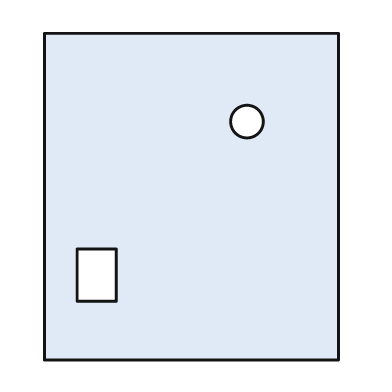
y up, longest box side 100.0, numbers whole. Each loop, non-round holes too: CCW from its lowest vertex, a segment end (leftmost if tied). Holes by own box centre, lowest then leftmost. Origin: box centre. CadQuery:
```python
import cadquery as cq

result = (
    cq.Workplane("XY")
    .moveTo(-45.0, -50.0)
    .lineTo(45.0, -50.0)
    .lineTo(45.0, 50.0)
    .lineTo(-45.0, 50.0)
    .close()
    .moveTo(-35.0, -32.0)
    .lineTo(-23.0, -32.0)
    .lineTo(-23.0, -16.0)
    .lineTo(-35.0, -16.0)
    .close()
    .moveTo(17.0, 23.0)
    .circle(5.0)
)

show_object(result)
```